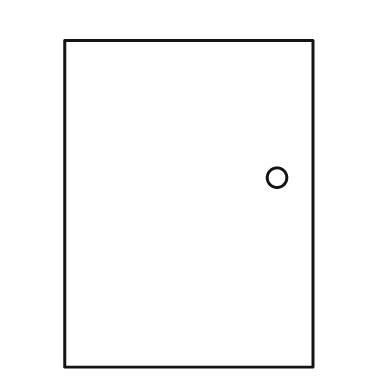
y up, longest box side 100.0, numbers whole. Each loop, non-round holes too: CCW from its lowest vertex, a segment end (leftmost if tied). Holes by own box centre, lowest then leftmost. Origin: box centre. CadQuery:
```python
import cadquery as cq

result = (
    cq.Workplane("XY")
    .moveTo(-38.0, -50.0)
    .lineTo(38.0, -50.0)
    .lineTo(38.0, 50.0)
    .lineTo(-38.0, 50.0)
    .close()
    .moveTo(27.0, 8.0)
    .circle(3.0)
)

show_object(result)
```